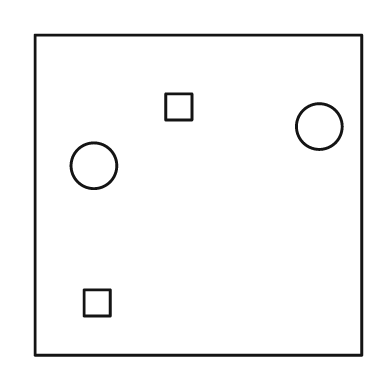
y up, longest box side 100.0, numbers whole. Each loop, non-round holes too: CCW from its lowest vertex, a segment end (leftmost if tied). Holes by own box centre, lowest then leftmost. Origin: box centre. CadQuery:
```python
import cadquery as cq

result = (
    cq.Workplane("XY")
    .moveTo(-50.0, -49.0)
    .lineTo(50.0, -49.0)
    .lineTo(50.0, 49.0)
    .lineTo(-50.0, 49.0)
    .close()
    .moveTo(-35.0, -37.0)
    .lineTo(-27.0, -37.0)
    .lineTo(-27.0, -29.0)
    .lineTo(-35.0, -29.0)
    .close()
    .moveTo(-32.0, 9.0)
    .circle(7.0)
    .moveTo(37.0, 21.0)
    .circle(7.0)
    .moveTo(-10.0, 23.0)
    .lineTo(-2.0, 23.0)
    .lineTo(-2.0, 31.0)
    .lineTo(-10.0, 31.0)
    .close()
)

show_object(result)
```